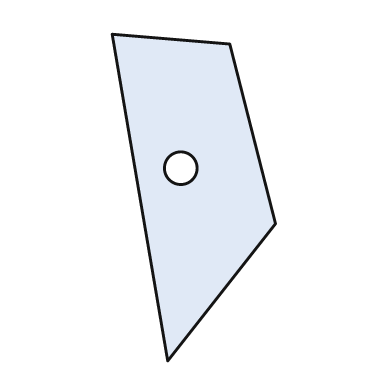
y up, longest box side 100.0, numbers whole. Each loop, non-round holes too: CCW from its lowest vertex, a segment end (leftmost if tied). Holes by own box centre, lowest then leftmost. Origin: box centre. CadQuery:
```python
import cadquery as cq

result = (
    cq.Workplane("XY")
    .moveTo(-8.0, -50.0)
    .lineTo(25.0, -8.0)
    .lineTo(11.0, 47.0)
    .lineTo(-25.0, 50.0)
    .close()
    .moveTo(-4.0, 9.0)
    .circle(5.0)
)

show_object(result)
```